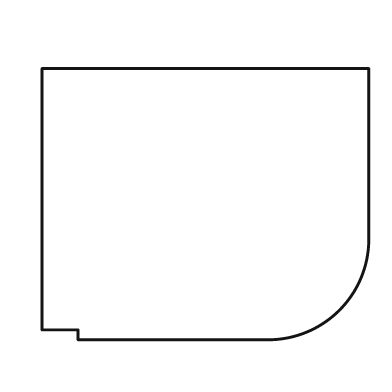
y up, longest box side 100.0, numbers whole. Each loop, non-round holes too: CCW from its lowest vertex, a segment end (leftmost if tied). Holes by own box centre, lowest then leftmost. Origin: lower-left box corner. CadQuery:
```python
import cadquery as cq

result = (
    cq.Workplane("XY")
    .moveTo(11.0, 0.0)
    .lineTo(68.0, 0.0)
    .threePointArc((91.0, 9.0), (100.0, 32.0))
    .lineTo(100.0, 83.0)
    .lineTo(0.0, 83.0)
    .lineTo(0.0, 3.0)
    .lineTo(11.0, 3.0)
    .close()
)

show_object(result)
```